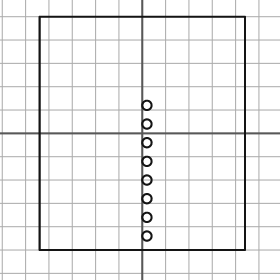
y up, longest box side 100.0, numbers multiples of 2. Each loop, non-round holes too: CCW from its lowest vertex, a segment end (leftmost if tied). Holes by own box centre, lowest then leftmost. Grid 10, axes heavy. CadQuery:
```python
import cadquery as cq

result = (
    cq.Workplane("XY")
    .moveTo(-44.0, -50.0)
    .lineTo(44.0, -50.0)
    .lineTo(44.0, 50.0)
    .lineTo(-44.0, 50.0)
    .close()
    .moveTo(2.0, -44.0)
    .circle(2.0)
    .moveTo(2.0, -36.0)
    .circle(2.0)
    .moveTo(2.0, -28.0)
    .circle(2.0)
    .moveTo(2.0, -20.0)
    .circle(2.0)
    .moveTo(2.0, -12.0)
    .circle(2.0)
    .moveTo(2.0, -4.0)
    .circle(2.0)
    .moveTo(2.0, 4.0)
    .circle(2.0)
    .moveTo(2.0, 12.0)
    .circle(2.0)
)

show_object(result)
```